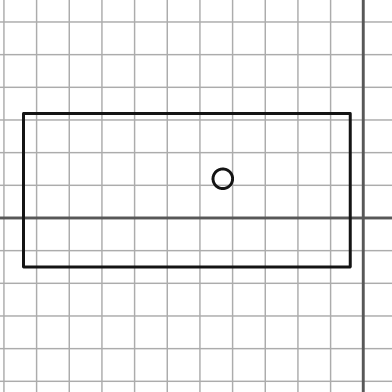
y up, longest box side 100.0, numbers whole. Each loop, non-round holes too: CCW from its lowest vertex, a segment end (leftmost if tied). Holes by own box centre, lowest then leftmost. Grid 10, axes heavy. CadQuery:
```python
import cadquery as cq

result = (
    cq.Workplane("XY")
    .moveTo(-104.0, -15.0)
    .lineTo(-4.0, -15.0)
    .lineTo(-4.0, 32.0)
    .lineTo(-104.0, 32.0)
    .close()
    .moveTo(-43.0, 12.0)
    .circle(3.0)
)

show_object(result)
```